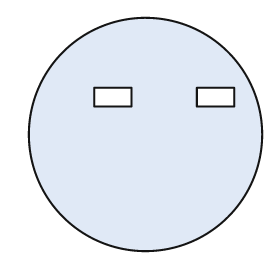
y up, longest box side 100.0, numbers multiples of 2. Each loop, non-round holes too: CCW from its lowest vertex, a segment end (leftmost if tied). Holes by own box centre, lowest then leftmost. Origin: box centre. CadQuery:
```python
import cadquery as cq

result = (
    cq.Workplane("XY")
    .moveTo(0.0, 0.0)
    .circle(50.0)
    .moveTo(-22.0, 12.0)
    .lineTo(-6.0, 12.0)
    .lineTo(-6.0, 20.0)
    .lineTo(-22.0, 20.0)
    .close()
    .moveTo(22.0, 12.0)
    .lineTo(38.0, 12.0)
    .lineTo(38.0, 20.0)
    .lineTo(22.0, 20.0)
    .close()
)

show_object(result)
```